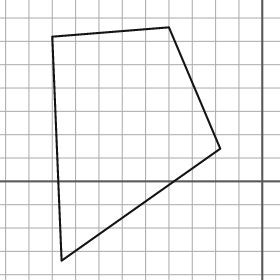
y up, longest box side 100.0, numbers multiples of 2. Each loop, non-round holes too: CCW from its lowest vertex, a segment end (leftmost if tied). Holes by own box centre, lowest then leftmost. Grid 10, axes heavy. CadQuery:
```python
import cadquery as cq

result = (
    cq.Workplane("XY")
    .moveTo(-86.0, -34.0)
    .lineTo(-18.0, 14.0)
    .lineTo(-40.0, 66.0)
    .lineTo(-90.0, 62.0)
    .close()
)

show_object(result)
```